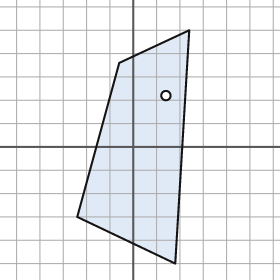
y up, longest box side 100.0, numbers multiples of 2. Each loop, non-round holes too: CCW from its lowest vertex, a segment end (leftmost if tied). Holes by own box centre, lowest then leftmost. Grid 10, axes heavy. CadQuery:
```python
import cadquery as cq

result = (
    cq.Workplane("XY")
    .moveTo(18.0, -50.0)
    .lineTo(24.0, 50.0)
    .lineTo(-6.0, 36.0)
    .lineTo(-24.0, -30.0)
    .close()
    .moveTo(14.0, 22.0)
    .circle(2.0)
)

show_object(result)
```